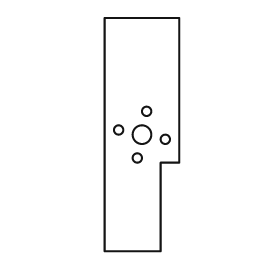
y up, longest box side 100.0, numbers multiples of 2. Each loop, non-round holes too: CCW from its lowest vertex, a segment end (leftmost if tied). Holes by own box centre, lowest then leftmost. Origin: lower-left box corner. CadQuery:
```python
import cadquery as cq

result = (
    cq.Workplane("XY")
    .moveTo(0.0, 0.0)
    .lineTo(24.0, 0.0)
    .lineTo(24.0, 38.0)
    .lineTo(32.0, 38.0)
    .lineTo(32.0, 100.0)
    .lineTo(0.0, 100.0)
    .close()
    .moveTo(14.0, 40.0)
    .circle(2.0)
    .moveTo(26.0, 48.0)
    .circle(2.0)
    .moveTo(16.0, 50.0)
    .circle(4.0)
    .moveTo(6.0, 52.0)
    .circle(2.0)
    .moveTo(18.0, 60.0)
    .circle(2.0)
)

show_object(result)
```